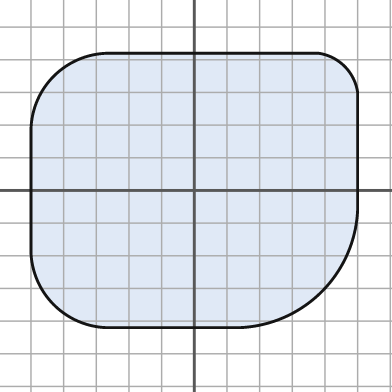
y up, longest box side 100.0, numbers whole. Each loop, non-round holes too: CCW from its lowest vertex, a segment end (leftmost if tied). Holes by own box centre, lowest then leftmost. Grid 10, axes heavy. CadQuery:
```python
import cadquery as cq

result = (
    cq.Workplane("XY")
    .moveTo(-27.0, -42.0)
    .lineTo(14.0, -42.0)
    .threePointArc((39.0, -31.0), (50.0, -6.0))
    .lineTo(50.0, 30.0)
    .threePointArc((46.0, 38.0), (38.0, 42.0))
    .lineTo(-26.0, 42.0)
    .threePointArc((-43.0, 35.0), (-50.0, 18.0))
    .lineTo(-50.0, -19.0)
    .threePointArc((-43.0, -35.0), (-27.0, -42.0))
    .close()
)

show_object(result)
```